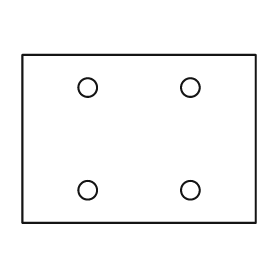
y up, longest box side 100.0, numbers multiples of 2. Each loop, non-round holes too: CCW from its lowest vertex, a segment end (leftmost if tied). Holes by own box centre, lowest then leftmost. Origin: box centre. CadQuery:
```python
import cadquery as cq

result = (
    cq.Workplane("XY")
    .moveTo(-50.0, -36.0)
    .lineTo(50.0, -36.0)
    .lineTo(50.0, 36.0)
    .lineTo(-50.0, 36.0)
    .close()
    .moveTo(-22.0, -22.0)
    .circle(4.0)
    .moveTo(22.0, -22.0)
    .circle(4.0)
    .moveTo(-22.0, 22.0)
    .circle(4.0)
    .moveTo(22.0, 22.0)
    .circle(4.0)
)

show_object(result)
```